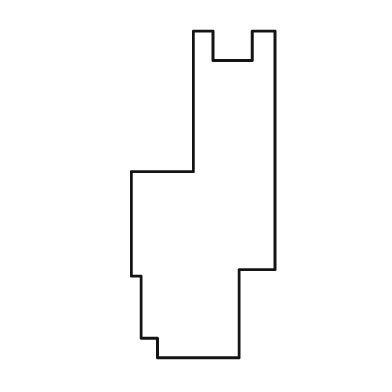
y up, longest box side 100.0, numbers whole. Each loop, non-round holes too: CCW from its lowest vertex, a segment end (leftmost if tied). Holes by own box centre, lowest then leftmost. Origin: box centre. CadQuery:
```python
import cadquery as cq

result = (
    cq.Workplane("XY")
    .moveTo(-14.0, -50.0)
    .lineTo(11.0, -50.0)
    .lineTo(11.0, -23.0)
    .lineTo(22.0, -23.0)
    .lineTo(22.0, 50.0)
    .lineTo(15.0, 50.0)
    .lineTo(15.0, 41.0)
    .lineTo(3.0, 41.0)
    .lineTo(3.0, 50.0)
    .lineTo(-3.0, 50.0)
    .lineTo(-3.0, 7.0)
    .lineTo(-22.0, 7.0)
    .lineTo(-22.0, -25.0)
    .lineTo(-19.0, -25.0)
    .lineTo(-19.0, -44.0)
    .lineTo(-14.0, -44.0)
    .close()
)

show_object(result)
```